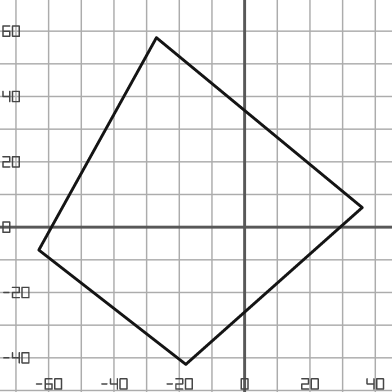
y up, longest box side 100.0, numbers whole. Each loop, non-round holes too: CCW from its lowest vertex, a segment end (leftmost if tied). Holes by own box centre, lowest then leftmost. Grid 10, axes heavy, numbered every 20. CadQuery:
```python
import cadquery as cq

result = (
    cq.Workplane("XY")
    .moveTo(-18.0, -42.0)
    .lineTo(36.0, 6.0)
    .lineTo(-27.0, 58.0)
    .lineTo(-63.0, -7.0)
    .close()
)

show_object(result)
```